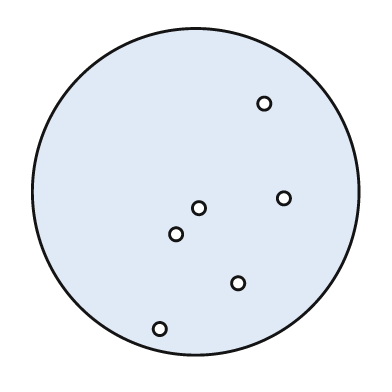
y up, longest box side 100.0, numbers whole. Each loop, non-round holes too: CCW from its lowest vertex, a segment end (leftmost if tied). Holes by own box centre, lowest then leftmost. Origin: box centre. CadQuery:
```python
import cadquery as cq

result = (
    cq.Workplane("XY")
    .moveTo(0.0, 0.0)
    .circle(50.0)
    .moveTo(-11.0, -42.0)
    .circle(2.0)
    .moveTo(13.0, -28.0)
    .circle(2.0)
    .moveTo(-6.0, -13.0)
    .circle(2.0)
    .moveTo(1.0, -5.0)
    .circle(2.0)
    .moveTo(27.0, -2.0)
    .circle(2.0)
    .moveTo(21.0, 27.0)
    .circle(2.0)
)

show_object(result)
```